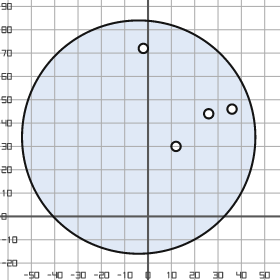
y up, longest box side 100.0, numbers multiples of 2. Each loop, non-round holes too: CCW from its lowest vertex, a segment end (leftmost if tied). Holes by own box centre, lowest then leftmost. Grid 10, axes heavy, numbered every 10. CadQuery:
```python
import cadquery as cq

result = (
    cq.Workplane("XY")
    .moveTo(-4.0, 34.0)
    .circle(50.0)
    .moveTo(12.0, 30.0)
    .circle(2.0)
    .moveTo(26.0, 44.0)
    .circle(2.0)
    .moveTo(36.0, 46.0)
    .circle(2.0)
    .moveTo(-2.0, 72.0)
    .circle(2.0)
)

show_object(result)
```